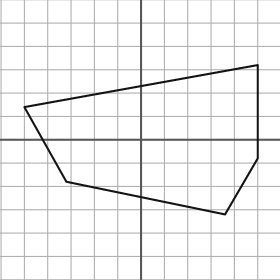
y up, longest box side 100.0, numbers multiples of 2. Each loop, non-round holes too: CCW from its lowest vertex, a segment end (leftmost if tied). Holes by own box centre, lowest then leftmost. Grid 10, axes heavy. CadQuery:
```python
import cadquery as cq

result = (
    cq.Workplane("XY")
    .moveTo(36.0, -32.0)
    .lineTo(50.0, -8.0)
    .lineTo(50.0, 32.0)
    .lineTo(-50.0, 14.0)
    .lineTo(-32.0, -18.0)
    .close()
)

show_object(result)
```